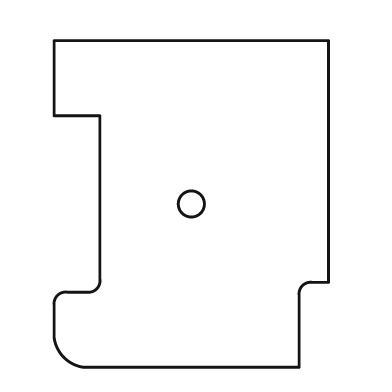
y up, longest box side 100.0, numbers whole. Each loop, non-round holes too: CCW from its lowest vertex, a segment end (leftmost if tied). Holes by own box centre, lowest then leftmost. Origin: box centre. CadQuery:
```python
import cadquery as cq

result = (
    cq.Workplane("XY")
    .moveTo(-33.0, -50.0)
    .lineTo(33.0, -50.0)
    .lineTo(33.0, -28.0)
    .threePointArc((34.0, -25.0), (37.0, -24.0))
    .lineTo(42.0, -24.0)
    .lineTo(42.0, 50.0)
    .lineTo(-42.0, 50.0)
    .lineTo(-42.0, 27.0)
    .lineTo(-28.0, 27.0)
    .lineTo(-28.0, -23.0)
    .threePointArc((-29.0, -26.0), (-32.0, -27.0))
    .lineTo(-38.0, -27.0)
    .threePointArc((-41.0, -28.0), (-42.0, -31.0))
    .lineTo(-42.0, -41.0)
    .threePointArc((-39.0, -47.0), (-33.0, -50.0))
    .close()
    .moveTo(0.0, 0.0)
    .circle(4.0)
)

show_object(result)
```